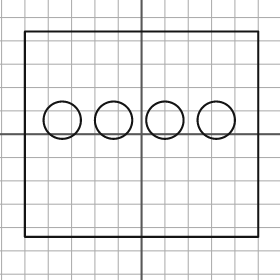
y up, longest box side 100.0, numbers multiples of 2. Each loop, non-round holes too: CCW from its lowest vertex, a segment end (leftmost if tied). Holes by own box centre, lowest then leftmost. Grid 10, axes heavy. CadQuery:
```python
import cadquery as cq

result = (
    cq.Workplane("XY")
    .moveTo(-50.0, -44.0)
    .lineTo(50.0, -44.0)
    .lineTo(50.0, 44.0)
    .lineTo(-50.0, 44.0)
    .close()
    .moveTo(-34.0, 6.0)
    .circle(8.0)
    .moveTo(-12.0, 6.0)
    .circle(8.0)
    .moveTo(10.0, 6.0)
    .circle(8.0)
    .moveTo(32.0, 6.0)
    .circle(8.0)
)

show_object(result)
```